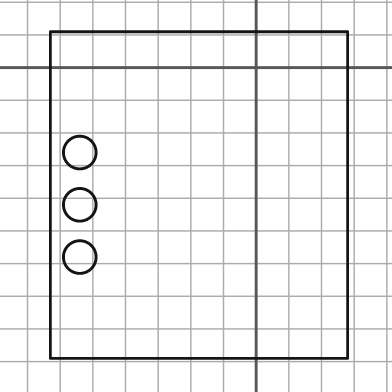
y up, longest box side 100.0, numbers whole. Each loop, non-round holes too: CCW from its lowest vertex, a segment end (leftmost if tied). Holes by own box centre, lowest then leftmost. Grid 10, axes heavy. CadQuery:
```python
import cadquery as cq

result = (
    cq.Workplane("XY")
    .moveTo(-63.0, -89.0)
    .lineTo(28.0, -89.0)
    .lineTo(28.0, 11.0)
    .lineTo(-63.0, 11.0)
    .close()
    .moveTo(-54.0, -58.0)
    .circle(5.0)
    .moveTo(-54.0, -42.0)
    .circle(5.0)
    .moveTo(-54.0, -26.0)
    .circle(5.0)
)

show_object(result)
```